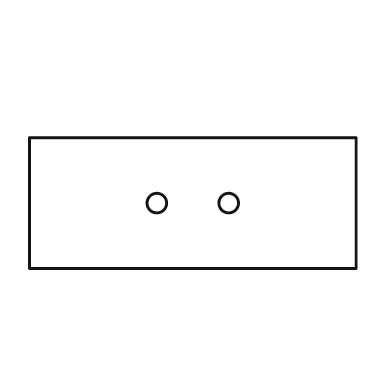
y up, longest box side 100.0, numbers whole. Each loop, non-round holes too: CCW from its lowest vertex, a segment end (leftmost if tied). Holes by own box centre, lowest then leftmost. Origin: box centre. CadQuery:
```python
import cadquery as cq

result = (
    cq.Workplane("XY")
    .moveTo(-50.0, -20.0)
    .lineTo(50.0, -20.0)
    .lineTo(50.0, 20.0)
    .lineTo(-50.0, 20.0)
    .close()
    .moveTo(-11.0, 0.0)
    .circle(3.0)
    .moveTo(11.0, 0.0)
    .circle(3.0)
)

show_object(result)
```